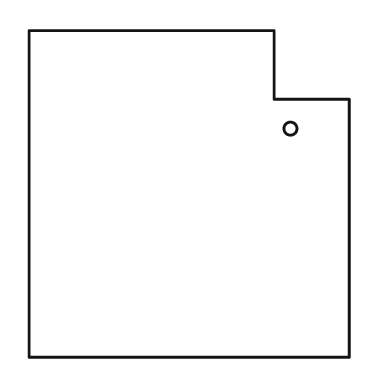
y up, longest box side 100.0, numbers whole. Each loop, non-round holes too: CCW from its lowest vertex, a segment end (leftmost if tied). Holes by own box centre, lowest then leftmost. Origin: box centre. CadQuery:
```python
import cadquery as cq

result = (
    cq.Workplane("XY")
    .moveTo(-49.0, -50.0)
    .lineTo(49.0, -50.0)
    .lineTo(49.0, 29.0)
    .lineTo(26.0, 29.0)
    .lineTo(26.0, 50.0)
    .lineTo(-49.0, 50.0)
    .close()
    .moveTo(31.0, 20.0)
    .circle(2.0)
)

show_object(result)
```